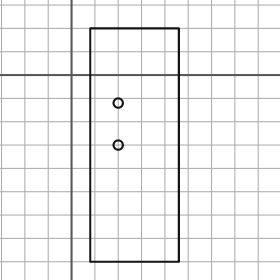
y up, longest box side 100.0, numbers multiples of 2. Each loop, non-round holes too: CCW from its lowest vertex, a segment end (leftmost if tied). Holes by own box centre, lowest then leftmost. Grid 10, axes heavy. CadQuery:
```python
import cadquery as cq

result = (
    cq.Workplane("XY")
    .moveTo(8.0, -80.0)
    .lineTo(46.0, -80.0)
    .lineTo(46.0, 20.0)
    .lineTo(8.0, 20.0)
    .close()
    .moveTo(20.0, -30.0)
    .circle(2.0)
    .moveTo(20.0, -12.0)
    .circle(2.0)
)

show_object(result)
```